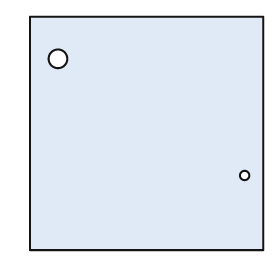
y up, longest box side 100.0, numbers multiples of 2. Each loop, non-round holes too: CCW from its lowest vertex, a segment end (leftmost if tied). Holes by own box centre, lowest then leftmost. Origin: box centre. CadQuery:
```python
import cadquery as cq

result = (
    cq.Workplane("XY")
    .moveTo(-50.0, -50.0)
    .lineTo(50.0, -50.0)
    .lineTo(50.0, 50.0)
    .lineTo(-50.0, 50.0)
    .close()
    .moveTo(42.0, -18.0)
    .circle(2.0)
    .moveTo(-38.0, 32.0)
    .circle(4.0)
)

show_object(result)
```